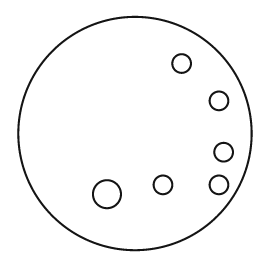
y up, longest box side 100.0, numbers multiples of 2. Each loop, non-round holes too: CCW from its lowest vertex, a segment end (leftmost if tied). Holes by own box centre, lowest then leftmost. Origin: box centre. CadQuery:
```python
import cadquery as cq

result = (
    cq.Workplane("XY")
    .moveTo(0.0, 0.0)
    .circle(50.0)
    .moveTo(-12.0, -26.0)
    .circle(6.0)
    .moveTo(12.0, -22.0)
    .circle(4.0)
    .moveTo(36.0, -22.0)
    .circle(4.0)
    .moveTo(38.0, -8.0)
    .circle(4.0)
    .moveTo(36.0, 14.0)
    .circle(4.0)
    .moveTo(20.0, 30.0)
    .circle(4.0)
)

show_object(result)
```